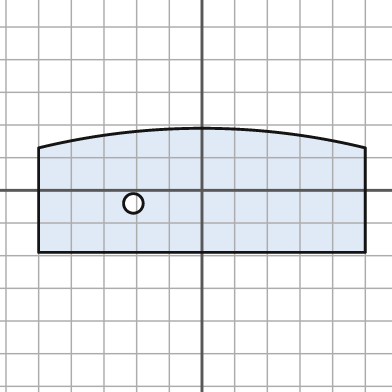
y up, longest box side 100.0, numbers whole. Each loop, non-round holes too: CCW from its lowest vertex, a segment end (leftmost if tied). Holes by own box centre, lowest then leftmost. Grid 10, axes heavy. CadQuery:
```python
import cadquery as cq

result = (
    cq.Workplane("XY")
    .moveTo(-50.0, -19.0)
    .lineTo(50.0, -19.0)
    .lineTo(50.0, 13.0)
    .threePointArc((0.0, 19.0), (-50.0, 13.0))
    .close()
    .moveTo(-21.0, -4.0)
    .circle(3.0)
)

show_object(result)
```